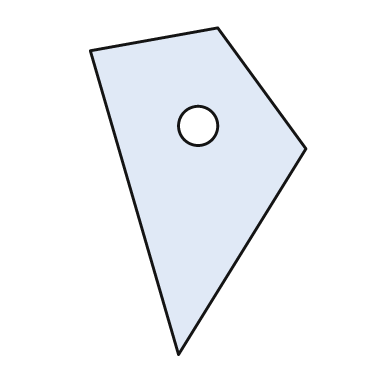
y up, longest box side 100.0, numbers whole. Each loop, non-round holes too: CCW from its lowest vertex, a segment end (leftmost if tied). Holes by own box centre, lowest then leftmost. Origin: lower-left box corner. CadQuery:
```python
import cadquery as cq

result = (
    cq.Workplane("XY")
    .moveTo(27.0, 0.0)
    .lineTo(66.0, 63.0)
    .lineTo(39.0, 100.0)
    .lineTo(0.0, 93.0)
    .close()
    .moveTo(33.0, 70.0)
    .circle(6.0)
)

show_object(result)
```